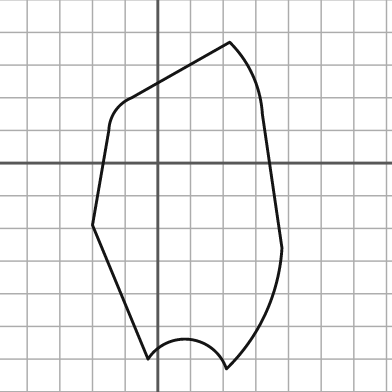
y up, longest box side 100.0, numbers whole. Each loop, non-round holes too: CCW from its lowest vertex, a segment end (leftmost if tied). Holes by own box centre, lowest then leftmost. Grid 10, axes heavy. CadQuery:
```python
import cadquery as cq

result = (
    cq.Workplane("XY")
    .moveTo(21.0, -63.0)
    .threePointArc((33.0, -46.0), (38.0, -26.0))
    .lineTo(32.0, 15.0)
    .threePointArc((29.0, 27.0), (22.0, 37.0))
    .lineTo(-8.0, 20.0)
    .threePointArc((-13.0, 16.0), (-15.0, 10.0))
    .lineTo(-20.0, -19.0)
    .lineTo(-3.0, -60.0)
    .threePointArc((10.0, -54.0), (21.0, -63.0))
    .close()
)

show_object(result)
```